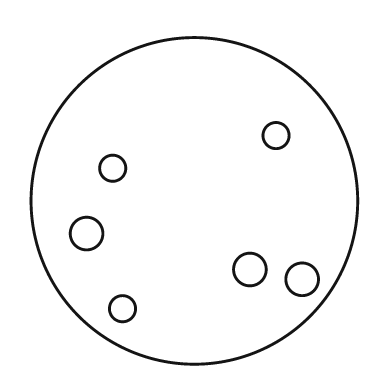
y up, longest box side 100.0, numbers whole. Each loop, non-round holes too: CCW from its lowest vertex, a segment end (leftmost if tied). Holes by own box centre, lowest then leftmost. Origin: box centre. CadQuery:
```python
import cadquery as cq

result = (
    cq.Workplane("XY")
    .moveTo(0.0, 0.0)
    .circle(50.0)
    .moveTo(-22.0, -33.0)
    .circle(4.0)
    .moveTo(33.0, -24.0)
    .circle(5.0)
    .moveTo(17.0, -21.0)
    .circle(5.0)
    .moveTo(-33.0, -10.0)
    .circle(5.0)
    .moveTo(-25.0, 10.0)
    .circle(4.0)
    .moveTo(25.0, 20.0)
    .circle(4.0)
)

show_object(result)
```